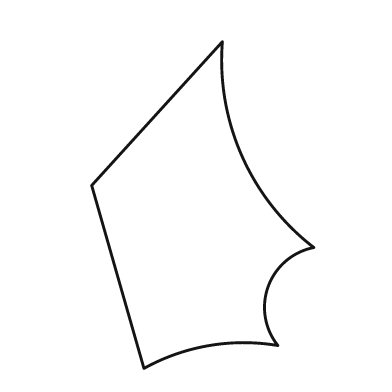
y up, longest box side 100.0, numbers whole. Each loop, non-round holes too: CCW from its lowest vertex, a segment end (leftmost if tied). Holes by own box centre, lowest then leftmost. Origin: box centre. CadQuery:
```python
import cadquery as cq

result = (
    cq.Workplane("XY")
    .moveTo(-18.0, -50.0)
    .threePointArc((2.0, -43.0), (23.0, -43.0))
    .threePointArc((20.0, -25.0), (34.0, -13.0))
    .threePointArc((12.0, 15.0), (6.0, 50.0))
    .lineTo(-34.0, 6.0)
    .close()
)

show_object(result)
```